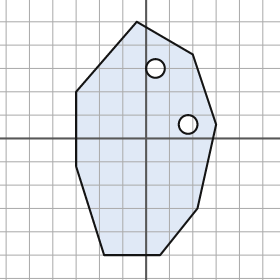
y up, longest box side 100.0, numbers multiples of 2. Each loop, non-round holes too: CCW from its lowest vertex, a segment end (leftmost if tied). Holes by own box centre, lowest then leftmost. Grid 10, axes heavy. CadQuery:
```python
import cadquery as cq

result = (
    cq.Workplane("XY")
    .moveTo(-18.0, -50.0)
    .lineTo(6.0, -50.0)
    .lineTo(22.0, -30.0)
    .lineTo(30.0, 6.0)
    .lineTo(20.0, 36.0)
    .lineTo(-4.0, 50.0)
    .lineTo(-30.0, 20.0)
    .lineTo(-30.0, -12.0)
    .close()
    .moveTo(18.0, 6.0)
    .circle(4.0)
    .moveTo(4.0, 30.0)
    .circle(4.0)
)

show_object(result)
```